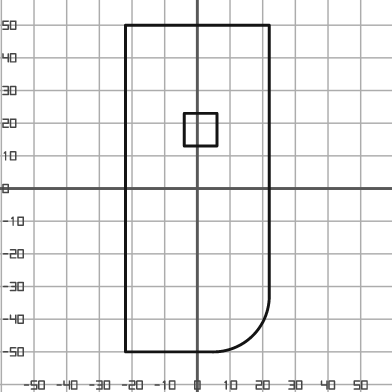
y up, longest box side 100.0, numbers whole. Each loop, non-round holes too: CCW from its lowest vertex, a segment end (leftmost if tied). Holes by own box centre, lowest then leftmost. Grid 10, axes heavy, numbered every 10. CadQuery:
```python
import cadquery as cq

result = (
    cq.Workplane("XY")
    .moveTo(-22.0, -50.0)
    .lineTo(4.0, -50.0)
    .threePointArc((17.0, -45.0), (22.0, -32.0))
    .lineTo(22.0, 50.0)
    .lineTo(-22.0, 50.0)
    .close()
    .moveTo(-4.0, 13.0)
    .lineTo(6.0, 13.0)
    .lineTo(6.0, 23.0)
    .lineTo(-4.0, 23.0)
    .close()
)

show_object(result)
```